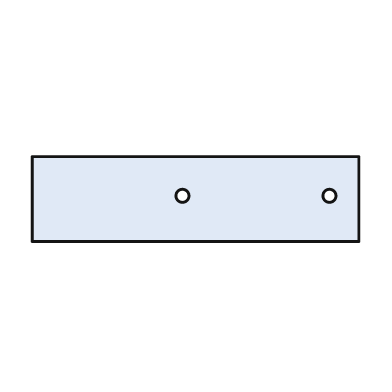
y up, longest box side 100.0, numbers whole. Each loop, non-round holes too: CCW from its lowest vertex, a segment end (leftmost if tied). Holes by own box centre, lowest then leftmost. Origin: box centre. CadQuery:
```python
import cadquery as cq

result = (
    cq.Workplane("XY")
    .moveTo(-50.0, -13.0)
    .lineTo(50.0, -13.0)
    .lineTo(50.0, 13.0)
    .lineTo(-50.0, 13.0)
    .close()
    .moveTo(-4.0, 1.0)
    .circle(2.0)
    .moveTo(41.0, 1.0)
    .circle(2.0)
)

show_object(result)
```